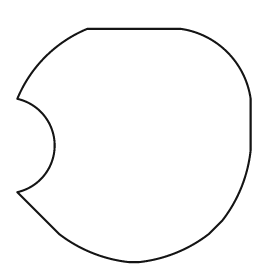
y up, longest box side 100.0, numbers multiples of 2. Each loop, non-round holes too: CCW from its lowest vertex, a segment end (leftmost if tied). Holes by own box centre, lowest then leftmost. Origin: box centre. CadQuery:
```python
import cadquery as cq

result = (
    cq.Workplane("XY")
    .moveTo(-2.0, -50.0)
    .lineTo(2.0, -50.0)
    .threePointArc((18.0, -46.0), (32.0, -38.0))
    .lineTo(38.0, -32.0)
    .threePointArc((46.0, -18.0), (50.0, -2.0))
    .lineTo(50.0, 20.0)
    .threePointArc((40.0, 40.0), (20.0, 50.0))
    .lineTo(-20.0, 50.0)
    .threePointArc((-38.0, 38.0), (-50.0, 20.0))
    .threePointArc((-34.0, 0.0), (-50.0, -20.0))
    .lineTo(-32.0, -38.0)
    .threePointArc((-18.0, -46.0), (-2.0, -50.0))
    .close()
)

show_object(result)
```